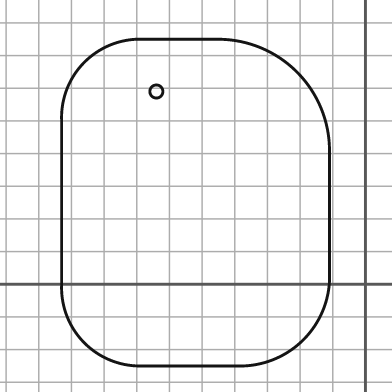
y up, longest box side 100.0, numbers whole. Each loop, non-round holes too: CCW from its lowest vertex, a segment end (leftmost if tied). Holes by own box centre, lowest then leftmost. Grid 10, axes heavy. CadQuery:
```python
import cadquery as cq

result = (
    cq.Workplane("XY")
    .moveTo(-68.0, -25.0)
    .lineTo(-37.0, -25.0)
    .threePointArc((-19.0, -17.0), (-11.0, 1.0))
    .lineTo(-11.0, 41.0)
    .threePointArc((-21.0, 65.0), (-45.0, 75.0))
    .lineTo(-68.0, 75.0)
    .threePointArc((-86.0, 68.0), (-93.0, 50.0))
    .lineTo(-93.0, 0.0)
    .threePointArc((-86.0, -18.0), (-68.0, -25.0))
    .close()
    .moveTo(-64.0, 59.0)
    .circle(2.0)
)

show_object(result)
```